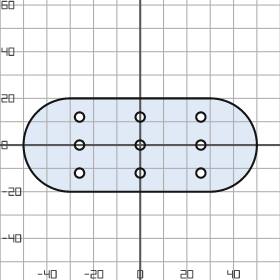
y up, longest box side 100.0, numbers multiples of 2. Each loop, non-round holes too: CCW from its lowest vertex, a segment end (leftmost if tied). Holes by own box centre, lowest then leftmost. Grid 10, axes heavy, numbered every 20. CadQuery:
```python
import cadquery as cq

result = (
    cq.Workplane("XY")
    .moveTo(-30.0, -20.0)
    .lineTo(30.0, -20.0)
    .threePointArc((50.0, 0.0), (30.0, 20.0))
    .lineTo(-30.0, 20.0)
    .threePointArc((-50.0, 0.0), (-30.0, -20.0))
    .close()
    .moveTo(-26.0, -12.0)
    .circle(2.0)
    .moveTo(0.0, -12.0)
    .circle(2.0)
    .moveTo(26.0, -12.0)
    .circle(2.0)
    .moveTo(-26.0, 0.0)
    .circle(2.0)
    .moveTo(0.0, 0.0)
    .circle(2.0)
    .moveTo(26.0, 0.0)
    .circle(2.0)
    .moveTo(-26.0, 12.0)
    .circle(2.0)
    .moveTo(0.0, 12.0)
    .circle(2.0)
    .moveTo(26.0, 12.0)
    .circle(2.0)
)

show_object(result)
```